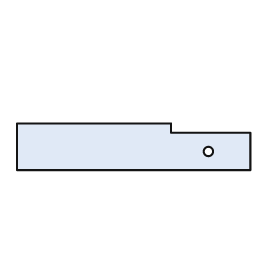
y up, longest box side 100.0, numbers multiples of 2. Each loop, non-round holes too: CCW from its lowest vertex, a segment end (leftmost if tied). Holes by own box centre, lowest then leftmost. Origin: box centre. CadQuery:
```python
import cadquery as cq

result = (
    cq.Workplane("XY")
    .moveTo(-50.0, -10.0)
    .lineTo(50.0, -10.0)
    .lineTo(50.0, 6.0)
    .lineTo(16.0, 6.0)
    .lineTo(16.0, 10.0)
    .lineTo(-50.0, 10.0)
    .close()
    .moveTo(32.0, -2.0)
    .circle(2.0)
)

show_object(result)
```